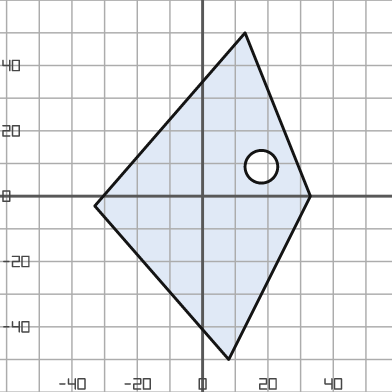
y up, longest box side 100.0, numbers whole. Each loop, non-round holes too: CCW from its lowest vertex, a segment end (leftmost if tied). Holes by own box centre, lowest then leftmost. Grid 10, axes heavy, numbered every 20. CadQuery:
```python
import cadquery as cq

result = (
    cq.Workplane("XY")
    .moveTo(8.0, -50.0)
    .lineTo(33.0, 0.0)
    .lineTo(13.0, 50.0)
    .lineTo(-33.0, -3.0)
    .close()
    .moveTo(18.0, 9.0)
    .circle(5.0)
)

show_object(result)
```